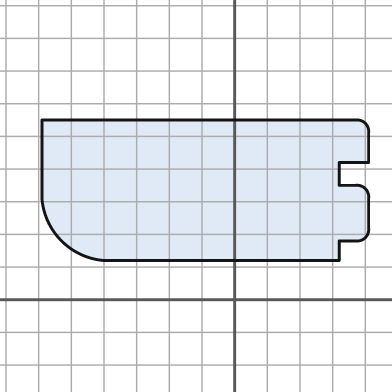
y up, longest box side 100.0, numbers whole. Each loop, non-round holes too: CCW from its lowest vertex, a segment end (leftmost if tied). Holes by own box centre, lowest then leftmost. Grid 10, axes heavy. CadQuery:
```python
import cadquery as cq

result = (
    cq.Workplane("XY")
    .moveTo(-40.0, 12.0)
    .lineTo(32.0, 12.0)
    .lineTo(32.0, 18.0)
    .lineTo(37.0, 18.0)
    .threePointArc((40.0, 19.0), (41.0, 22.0))
    .lineTo(41.0, 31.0)
    .threePointArc((40.0, 34.0), (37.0, 35.0))
    .lineTo(32.0, 35.0)
    .lineTo(32.0, 42.0)
    .lineTo(41.0, 42.0)
    .lineTo(41.0, 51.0)
    .threePointArc((40.0, 54.0), (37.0, 55.0))
    .lineTo(-59.0, 55.0)
    .lineTo(-59.0, 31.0)
    .threePointArc((-53.0, 18.0), (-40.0, 12.0))
    .close()
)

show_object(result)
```